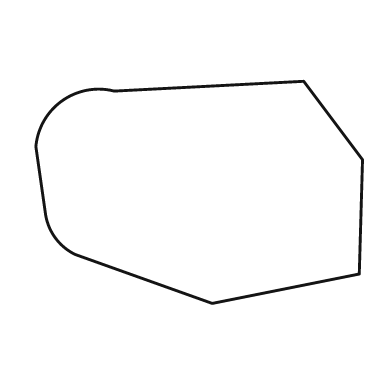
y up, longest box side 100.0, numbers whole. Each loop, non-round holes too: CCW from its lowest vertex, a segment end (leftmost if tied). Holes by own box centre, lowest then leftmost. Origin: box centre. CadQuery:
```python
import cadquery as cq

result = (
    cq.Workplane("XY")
    .moveTo(4.0, -34.0)
    .lineTo(49.0, -25.0)
    .lineTo(50.0, 10.0)
    .lineTo(32.0, 34.0)
    .lineTo(-26.0, 31.0)
    .threePointArc((-42.0, 28.0), (-50.0, 14.0))
    .lineTo(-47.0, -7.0)
    .threePointArc((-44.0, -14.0), (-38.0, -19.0))
    .close()
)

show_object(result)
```